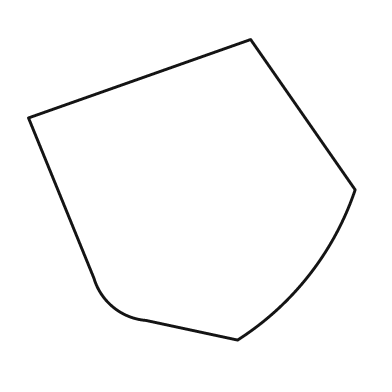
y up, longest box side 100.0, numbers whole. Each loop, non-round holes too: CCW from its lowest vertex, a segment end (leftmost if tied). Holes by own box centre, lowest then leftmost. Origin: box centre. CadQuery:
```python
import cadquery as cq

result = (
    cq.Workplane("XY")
    .moveTo(14.0, -46.0)
    .threePointArc((36.0, -26.0), (50.0, 0.0))
    .lineTo(18.0, 46.0)
    .lineTo(-50.0, 22.0)
    .lineTo(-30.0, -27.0)
    .threePointArc((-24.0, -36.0), (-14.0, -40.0))
    .close()
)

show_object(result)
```